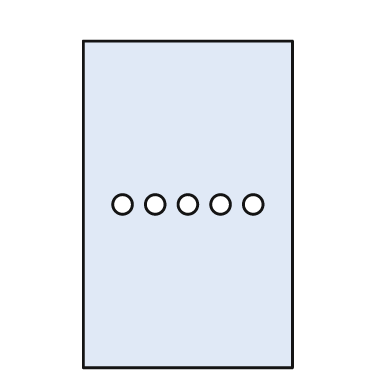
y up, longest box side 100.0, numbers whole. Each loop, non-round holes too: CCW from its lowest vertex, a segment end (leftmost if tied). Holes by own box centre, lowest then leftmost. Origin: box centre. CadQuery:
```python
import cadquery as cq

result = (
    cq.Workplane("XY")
    .moveTo(-32.0, -50.0)
    .lineTo(32.0, -50.0)
    .lineTo(32.0, 50.0)
    .lineTo(-32.0, 50.0)
    .close()
    .moveTo(-20.0, 0.0)
    .circle(3.0)
    .moveTo(-10.0, 0.0)
    .circle(3.0)
    .moveTo(0.0, 0.0)
    .circle(3.0)
    .moveTo(10.0, 0.0)
    .circle(3.0)
    .moveTo(20.0, 0.0)
    .circle(3.0)
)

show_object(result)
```